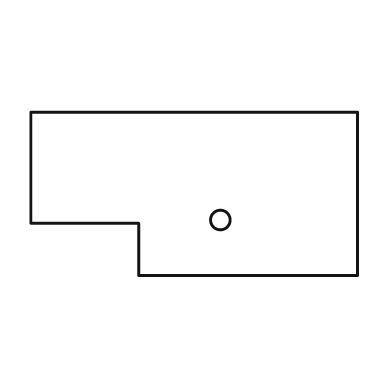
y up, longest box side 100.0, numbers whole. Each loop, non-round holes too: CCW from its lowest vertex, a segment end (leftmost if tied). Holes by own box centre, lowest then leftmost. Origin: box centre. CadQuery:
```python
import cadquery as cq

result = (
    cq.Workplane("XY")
    .moveTo(-17.0, -25.0)
    .lineTo(50.0, -25.0)
    .lineTo(50.0, 25.0)
    .lineTo(-50.0, 25.0)
    .lineTo(-50.0, -9.0)
    .lineTo(-17.0, -9.0)
    .close()
    .moveTo(8.0, -8.0)
    .circle(3.0)
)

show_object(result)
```